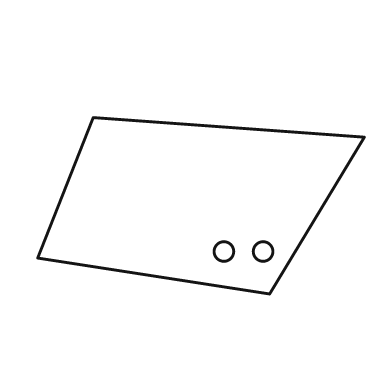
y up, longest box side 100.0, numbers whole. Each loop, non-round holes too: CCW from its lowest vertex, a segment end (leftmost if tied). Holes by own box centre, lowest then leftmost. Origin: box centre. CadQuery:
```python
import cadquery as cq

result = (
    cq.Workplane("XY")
    .moveTo(21.0, -27.0)
    .lineTo(50.0, 21.0)
    .lineTo(-33.0, 27.0)
    .lineTo(-50.0, -16.0)
    .close()
    .moveTo(7.0, -14.0)
    .circle(3.0)
    .moveTo(19.0, -14.0)
    .circle(3.0)
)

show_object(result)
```